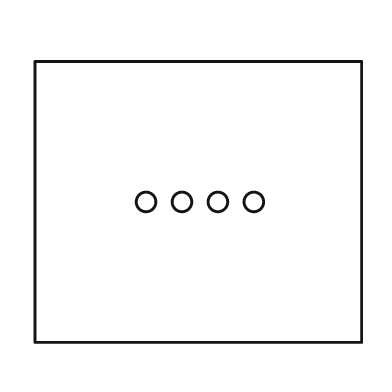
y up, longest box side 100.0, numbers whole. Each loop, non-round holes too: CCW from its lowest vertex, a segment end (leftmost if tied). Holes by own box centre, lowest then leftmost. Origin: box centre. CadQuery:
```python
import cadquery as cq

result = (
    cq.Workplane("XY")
    .moveTo(-50.0, -43.0)
    .lineTo(50.0, -43.0)
    .lineTo(50.0, 43.0)
    .lineTo(-50.0, 43.0)
    .close()
    .moveTo(-16.0, 0.0)
    .circle(3.0)
    .moveTo(-5.0, 0.0)
    .circle(3.0)
    .moveTo(6.0, 0.0)
    .circle(3.0)
    .moveTo(17.0, 0.0)
    .circle(3.0)
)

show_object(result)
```